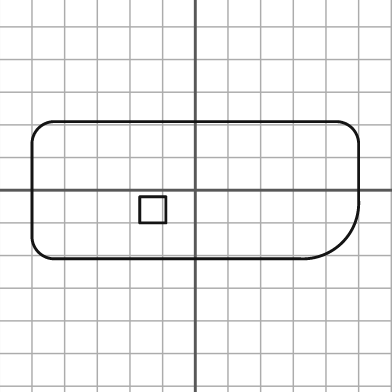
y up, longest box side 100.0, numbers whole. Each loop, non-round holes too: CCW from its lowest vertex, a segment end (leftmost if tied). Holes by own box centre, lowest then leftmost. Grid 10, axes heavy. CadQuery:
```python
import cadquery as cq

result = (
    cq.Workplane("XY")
    .moveTo(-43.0, -21.0)
    .lineTo(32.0, -21.0)
    .threePointArc((45.0, -16.0), (50.0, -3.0))
    .lineTo(50.0, 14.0)
    .threePointArc((48.0, 19.0), (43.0, 21.0))
    .lineTo(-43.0, 21.0)
    .threePointArc((-48.0, 19.0), (-50.0, 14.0))
    .lineTo(-50.0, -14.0)
    .threePointArc((-48.0, -19.0), (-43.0, -21.0))
    .close()
    .moveTo(-17.0, -10.0)
    .lineTo(-9.0, -10.0)
    .lineTo(-9.0, -2.0)
    .lineTo(-17.0, -2.0)
    .close()
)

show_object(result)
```